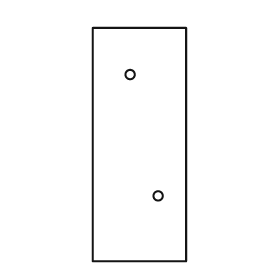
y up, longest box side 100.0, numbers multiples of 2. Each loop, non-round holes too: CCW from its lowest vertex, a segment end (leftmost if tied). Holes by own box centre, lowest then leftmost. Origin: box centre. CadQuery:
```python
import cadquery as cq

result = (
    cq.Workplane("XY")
    .moveTo(-20.0, -50.0)
    .lineTo(20.0, -50.0)
    .lineTo(20.0, 50.0)
    .lineTo(-20.0, 50.0)
    .close()
    .moveTo(8.0, -22.0)
    .circle(2.0)
    .moveTo(-4.0, 30.0)
    .circle(2.0)
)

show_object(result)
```